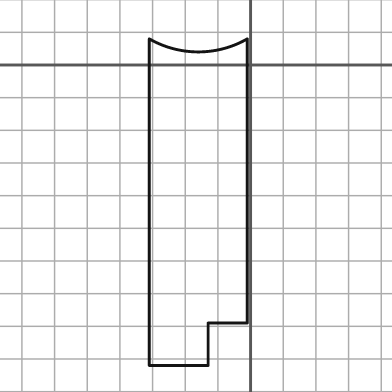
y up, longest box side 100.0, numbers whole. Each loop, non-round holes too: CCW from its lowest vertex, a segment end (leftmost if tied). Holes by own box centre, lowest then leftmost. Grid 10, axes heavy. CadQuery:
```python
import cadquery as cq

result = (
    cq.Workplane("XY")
    .moveTo(-31.0, -92.0)
    .lineTo(-13.0, -92.0)
    .lineTo(-13.0, -79.0)
    .lineTo(-1.0, -79.0)
    .lineTo(-1.0, 8.0)
    .threePointArc((-16.0, 4.0), (-31.0, 8.0))
    .close()
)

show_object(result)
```